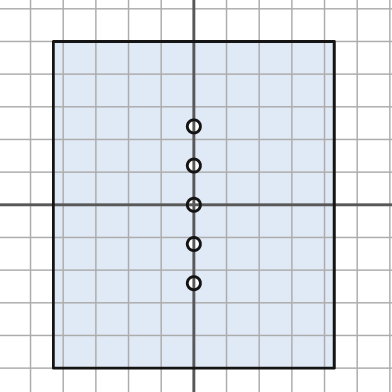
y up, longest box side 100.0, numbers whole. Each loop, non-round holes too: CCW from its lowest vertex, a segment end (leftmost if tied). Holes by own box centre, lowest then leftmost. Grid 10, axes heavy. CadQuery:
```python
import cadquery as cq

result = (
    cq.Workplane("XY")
    .moveTo(-43.0, -50.0)
    .lineTo(43.0, -50.0)
    .lineTo(43.0, 50.0)
    .lineTo(-43.0, 50.0)
    .close()
    .moveTo(0.0, -24.0)
    .circle(2.0)
    .moveTo(0.0, -12.0)
    .circle(2.0)
    .moveTo(0.0, 0.0)
    .circle(2.0)
    .moveTo(0.0, 12.0)
    .circle(2.0)
    .moveTo(0.0, 24.0)
    .circle(2.0)
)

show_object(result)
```